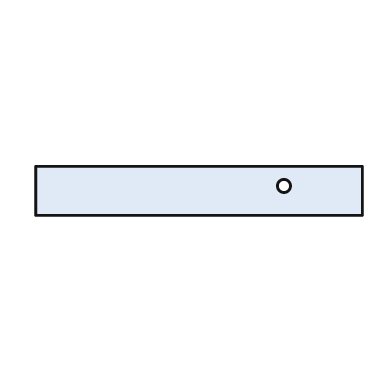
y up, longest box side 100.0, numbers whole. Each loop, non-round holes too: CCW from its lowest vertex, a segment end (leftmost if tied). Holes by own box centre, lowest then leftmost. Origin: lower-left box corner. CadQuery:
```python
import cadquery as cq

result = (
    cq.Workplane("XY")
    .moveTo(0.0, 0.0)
    .lineTo(100.0, 0.0)
    .lineTo(100.0, 15.0)
    .lineTo(0.0, 15.0)
    .close()
    .moveTo(76.0, 9.0)
    .circle(2.0)
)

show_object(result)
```